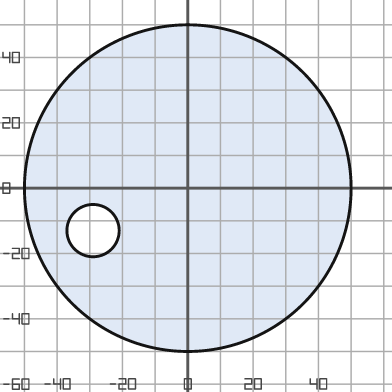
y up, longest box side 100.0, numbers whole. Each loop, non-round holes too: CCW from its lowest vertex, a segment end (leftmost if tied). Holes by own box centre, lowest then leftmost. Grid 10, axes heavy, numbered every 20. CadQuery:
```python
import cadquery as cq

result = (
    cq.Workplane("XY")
    .moveTo(0.0, 0.0)
    .circle(50.0)
    .moveTo(-29.0, -13.0)
    .circle(8.0)
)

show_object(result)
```